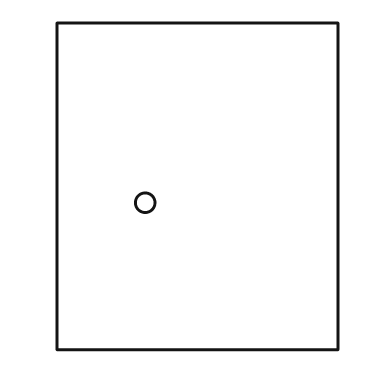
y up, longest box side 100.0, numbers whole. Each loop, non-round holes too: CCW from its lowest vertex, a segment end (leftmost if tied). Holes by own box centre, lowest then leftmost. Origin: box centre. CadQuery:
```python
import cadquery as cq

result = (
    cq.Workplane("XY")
    .moveTo(-43.0, -50.0)
    .lineTo(43.0, -50.0)
    .lineTo(43.0, 50.0)
    .lineTo(-43.0, 50.0)
    .close()
    .moveTo(-16.0, -5.0)
    .circle(3.0)
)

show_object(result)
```